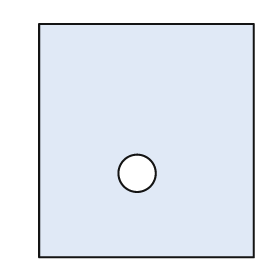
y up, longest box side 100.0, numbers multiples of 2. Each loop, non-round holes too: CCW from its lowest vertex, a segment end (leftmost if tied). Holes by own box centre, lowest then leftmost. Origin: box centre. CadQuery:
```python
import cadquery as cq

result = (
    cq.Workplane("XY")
    .moveTo(-46.0, -50.0)
    .lineTo(46.0, -50.0)
    .lineTo(46.0, 50.0)
    .lineTo(-46.0, 50.0)
    .close()
    .moveTo(-4.0, -14.0)
    .circle(8.0)
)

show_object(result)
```